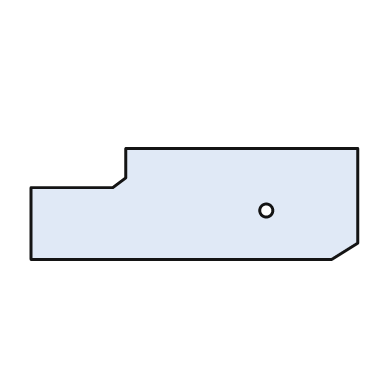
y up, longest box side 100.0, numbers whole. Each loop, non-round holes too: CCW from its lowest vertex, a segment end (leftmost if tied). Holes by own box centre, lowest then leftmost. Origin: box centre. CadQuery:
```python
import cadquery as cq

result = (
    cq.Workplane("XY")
    .moveTo(-50.0, -17.0)
    .lineTo(42.0, -17.0)
    .lineTo(50.0, -12.0)
    .lineTo(50.0, 17.0)
    .lineTo(-21.0, 17.0)
    .lineTo(-21.0, 8.0)
    .lineTo(-25.0, 5.0)
    .lineTo(-50.0, 5.0)
    .close()
    .moveTo(22.0, -2.0)
    .circle(2.0)
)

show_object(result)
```